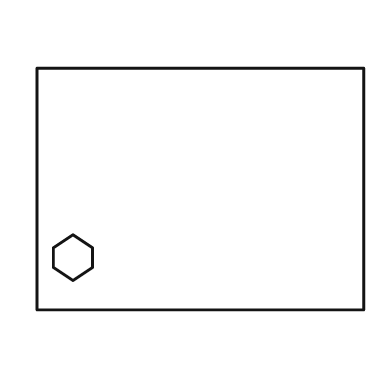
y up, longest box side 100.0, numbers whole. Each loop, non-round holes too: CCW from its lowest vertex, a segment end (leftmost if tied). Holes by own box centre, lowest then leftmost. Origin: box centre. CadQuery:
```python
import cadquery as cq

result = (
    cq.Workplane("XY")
    .moveTo(-50.0, -37.0)
    .lineTo(50.0, -37.0)
    .lineTo(50.0, 37.0)
    .lineTo(-50.0, 37.0)
    .close()
    .moveTo(-39.0, -28.0)
    .lineTo(-33.0, -24.0)
    .lineTo(-33.0, -18.0)
    .lineTo(-39.0, -14.0)
    .lineTo(-45.0, -18.0)
    .lineTo(-45.0, -24.0)
    .close()
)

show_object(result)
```